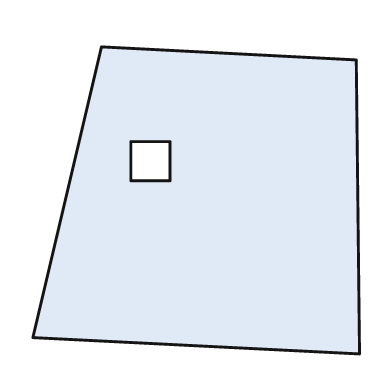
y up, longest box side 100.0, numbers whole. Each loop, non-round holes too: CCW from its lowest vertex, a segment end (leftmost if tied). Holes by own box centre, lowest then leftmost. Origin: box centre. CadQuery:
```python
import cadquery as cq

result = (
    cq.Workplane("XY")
    .moveTo(50.0, -47.0)
    .lineTo(49.0, 43.0)
    .lineTo(-29.0, 47.0)
    .lineTo(-50.0, -42.0)
    .close()
    .moveTo(-20.0, 6.0)
    .lineTo(-8.0, 6.0)
    .lineTo(-8.0, 18.0)
    .lineTo(-20.0, 18.0)
    .close()
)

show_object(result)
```